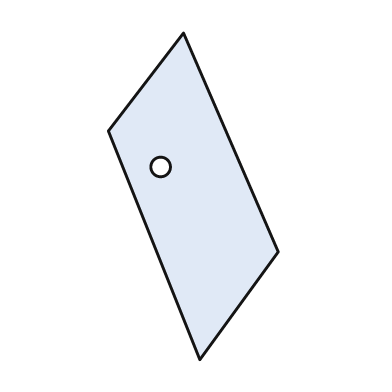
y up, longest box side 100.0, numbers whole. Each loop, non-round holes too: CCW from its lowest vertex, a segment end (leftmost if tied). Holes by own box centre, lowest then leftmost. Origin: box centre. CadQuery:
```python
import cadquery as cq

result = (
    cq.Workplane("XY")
    .moveTo(2.0, -50.0)
    .lineTo(26.0, -17.0)
    .lineTo(-3.0, 50.0)
    .lineTo(-26.0, 20.0)
    .close()
    .moveTo(-10.0, 9.0)
    .circle(3.0)
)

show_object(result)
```